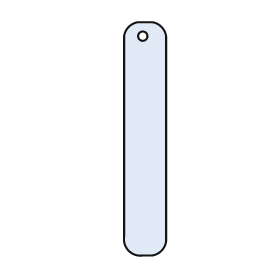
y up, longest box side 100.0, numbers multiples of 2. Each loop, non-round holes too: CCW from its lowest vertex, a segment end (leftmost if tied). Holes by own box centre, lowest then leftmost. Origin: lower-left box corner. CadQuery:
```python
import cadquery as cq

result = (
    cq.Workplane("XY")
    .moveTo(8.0, 0.0)
    .lineTo(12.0, 0.0)
    .threePointArc((16.0, 2.0), (18.0, 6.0))
    .lineTo(18.0, 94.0)
    .threePointArc((16.0, 98.0), (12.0, 100.0))
    .lineTo(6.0, 100.0)
    .threePointArc((2.0, 98.0), (0.0, 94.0))
    .lineTo(0.0, 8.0)
    .threePointArc((2.0, 2.0), (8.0, 0.0))
    .close()
    .moveTo(8.0, 94.0)
    .circle(2.0)
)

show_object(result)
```